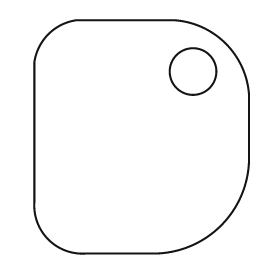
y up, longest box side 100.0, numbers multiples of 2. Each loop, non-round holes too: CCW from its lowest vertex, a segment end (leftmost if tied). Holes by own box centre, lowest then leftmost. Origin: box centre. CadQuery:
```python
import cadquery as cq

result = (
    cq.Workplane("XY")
    .moveTo(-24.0, -50.0)
    .lineTo(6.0, -50.0)
    .threePointArc((34.0, -38.0), (46.0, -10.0))
    .lineTo(46.0, 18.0)
    .threePointArc((36.0, 40.0), (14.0, 50.0))
    .lineTo(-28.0, 50.0)
    .threePointArc((-40.0, 44.0), (-46.0, 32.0))
    .lineTo(-46.0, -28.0)
    .threePointArc((-40.0, -44.0), (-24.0, -50.0))
    .close()
    .moveTo(22.0, 28.0)
    .circle(10.0)
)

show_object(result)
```